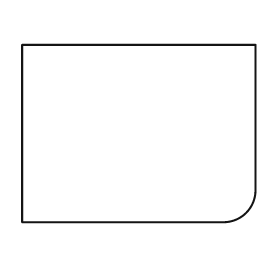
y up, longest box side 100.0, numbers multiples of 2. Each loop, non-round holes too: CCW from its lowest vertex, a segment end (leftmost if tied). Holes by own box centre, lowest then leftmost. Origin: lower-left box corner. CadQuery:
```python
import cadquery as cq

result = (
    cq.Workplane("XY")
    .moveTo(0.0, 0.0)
    .lineTo(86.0, 0.0)
    .threePointArc((96.0, 4.0), (100.0, 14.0))
    .lineTo(100.0, 76.0)
    .lineTo(0.0, 76.0)
    .close()
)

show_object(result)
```